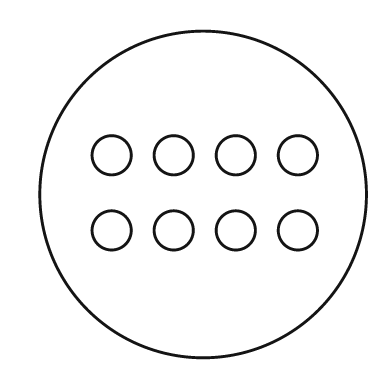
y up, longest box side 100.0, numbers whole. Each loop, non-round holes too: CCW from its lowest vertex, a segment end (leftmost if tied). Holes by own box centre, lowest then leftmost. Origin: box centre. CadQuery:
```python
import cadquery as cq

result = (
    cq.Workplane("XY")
    .moveTo(0.0, 0.0)
    .circle(50.0)
    .moveTo(-28.0, -11.0)
    .circle(6.0)
    .moveTo(-9.0, -11.0)
    .circle(6.0)
    .moveTo(10.0, -11.0)
    .circle(6.0)
    .moveTo(29.0, -11.0)
    .circle(6.0)
    .moveTo(-28.0, 12.0)
    .circle(6.0)
    .moveTo(-9.0, 12.0)
    .circle(6.0)
    .moveTo(10.0, 12.0)
    .circle(6.0)
    .moveTo(29.0, 12.0)
    .circle(6.0)
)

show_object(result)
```